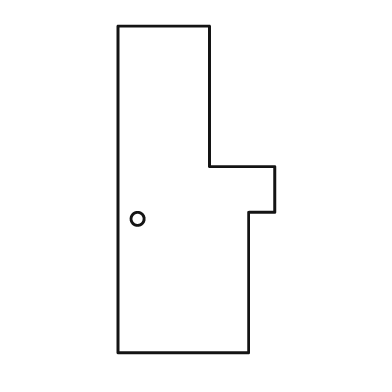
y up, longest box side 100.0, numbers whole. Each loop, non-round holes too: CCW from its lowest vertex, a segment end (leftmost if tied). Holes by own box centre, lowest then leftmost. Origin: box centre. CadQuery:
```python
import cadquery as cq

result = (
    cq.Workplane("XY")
    .moveTo(-24.0, -50.0)
    .lineTo(16.0, -50.0)
    .lineTo(16.0, -7.0)
    .lineTo(24.0, -7.0)
    .lineTo(24.0, 7.0)
    .lineTo(4.0, 7.0)
    .lineTo(4.0, 50.0)
    .lineTo(-24.0, 50.0)
    .close()
    .moveTo(-18.0, -9.0)
    .circle(2.0)
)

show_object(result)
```